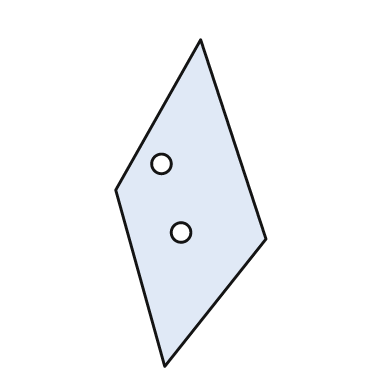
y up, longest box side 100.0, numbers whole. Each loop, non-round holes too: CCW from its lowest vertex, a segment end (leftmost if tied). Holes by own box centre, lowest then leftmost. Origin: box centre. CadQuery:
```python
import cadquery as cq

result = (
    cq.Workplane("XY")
    .moveTo(-8.0, -50.0)
    .lineTo(23.0, -11.0)
    .lineTo(3.0, 50.0)
    .lineTo(-23.0, 4.0)
    .close()
    .moveTo(-3.0, -9.0)
    .circle(3.0)
    .moveTo(-9.0, 12.0)
    .circle(3.0)
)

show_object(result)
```